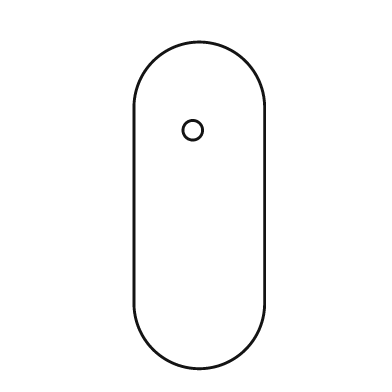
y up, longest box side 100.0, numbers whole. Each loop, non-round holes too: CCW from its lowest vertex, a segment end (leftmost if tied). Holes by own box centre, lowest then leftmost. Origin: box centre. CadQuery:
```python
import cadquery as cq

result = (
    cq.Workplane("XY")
    .moveTo(-20.0, -30.0)
    .threePointArc((0.0, -50.0), (20.0, -30.0))
    .lineTo(20.0, 30.0)
    .threePointArc((0.0, 50.0), (-20.0, 30.0))
    .close()
    .moveTo(-2.0, 23.0)
    .circle(3.0)
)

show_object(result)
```